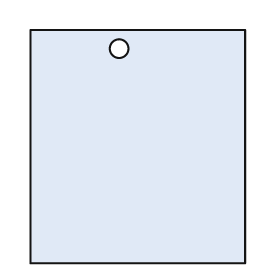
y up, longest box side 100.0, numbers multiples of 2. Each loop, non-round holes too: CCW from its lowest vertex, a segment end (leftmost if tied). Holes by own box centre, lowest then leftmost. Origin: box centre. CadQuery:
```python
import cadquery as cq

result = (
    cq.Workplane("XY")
    .moveTo(-46.0, -50.0)
    .lineTo(46.0, -50.0)
    .lineTo(46.0, 50.0)
    .lineTo(-46.0, 50.0)
    .close()
    .moveTo(-8.0, 42.0)
    .circle(4.0)
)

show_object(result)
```